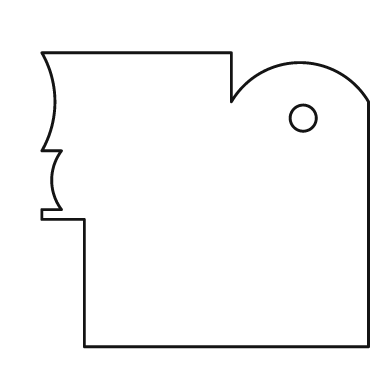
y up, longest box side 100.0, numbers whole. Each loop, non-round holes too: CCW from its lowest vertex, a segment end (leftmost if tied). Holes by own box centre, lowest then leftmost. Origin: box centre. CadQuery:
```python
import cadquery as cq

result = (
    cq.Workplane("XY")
    .moveTo(-37.0, -45.0)
    .lineTo(50.0, -45.0)
    .lineTo(50.0, 30.0)
    .threePointArc((29.0, 42.0), (8.0, 30.0))
    .lineTo(8.0, 45.0)
    .lineTo(-50.0, 45.0)
    .threePointArc((-46.0, 30.0), (-50.0, 15.0))
    .lineTo(-44.0, 15.0)
    .threePointArc((-47.0, 6.0), (-44.0, -3.0))
    .lineTo(-50.0, -3.0)
    .lineTo(-50.0, -6.0)
    .lineTo(-37.0, -6.0)
    .close()
    .moveTo(30.0, 25.0)
    .circle(4.0)
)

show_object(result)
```